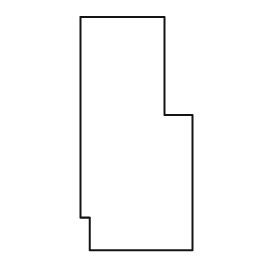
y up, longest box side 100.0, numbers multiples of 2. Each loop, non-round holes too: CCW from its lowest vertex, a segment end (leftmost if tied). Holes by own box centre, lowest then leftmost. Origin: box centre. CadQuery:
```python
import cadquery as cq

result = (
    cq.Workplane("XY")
    .moveTo(-20.0, -50.0)
    .lineTo(24.0, -50.0)
    .lineTo(24.0, 8.0)
    .lineTo(12.0, 8.0)
    .lineTo(12.0, 50.0)
    .lineTo(-24.0, 50.0)
    .lineTo(-24.0, -36.0)
    .lineTo(-20.0, -36.0)
    .close()
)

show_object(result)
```